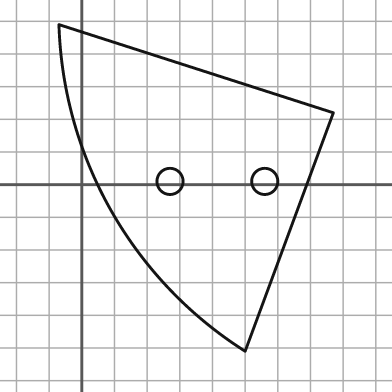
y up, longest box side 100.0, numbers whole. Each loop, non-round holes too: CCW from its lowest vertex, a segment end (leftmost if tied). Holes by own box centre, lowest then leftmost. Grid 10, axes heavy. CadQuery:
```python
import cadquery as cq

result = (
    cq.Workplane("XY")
    .moveTo(50.0, -51.0)
    .lineTo(77.0, 22.0)
    .lineTo(-7.0, 49.0)
    .threePointArc((9.0, -8.0), (50.0, -51.0))
    .close()
    .moveTo(27.0, 1.0)
    .circle(4.0)
    .moveTo(56.0, 1.0)
    .circle(4.0)
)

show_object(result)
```